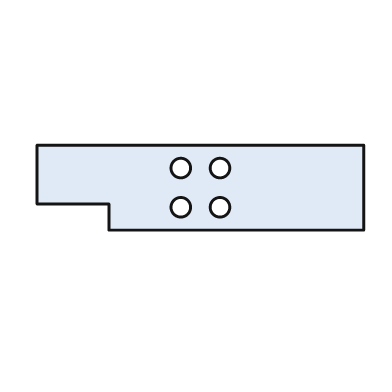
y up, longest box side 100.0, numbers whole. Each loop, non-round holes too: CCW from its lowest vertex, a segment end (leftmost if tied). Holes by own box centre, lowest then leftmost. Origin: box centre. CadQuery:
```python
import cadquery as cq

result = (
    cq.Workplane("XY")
    .moveTo(-28.0, -13.0)
    .lineTo(50.0, -13.0)
    .lineTo(50.0, 13.0)
    .lineTo(-50.0, 13.0)
    .lineTo(-50.0, -5.0)
    .lineTo(-28.0, -5.0)
    .close()
    .moveTo(-6.0, -6.0)
    .circle(3.0)
    .moveTo(6.0, -6.0)
    .circle(3.0)
    .moveTo(-6.0, 6.0)
    .circle(3.0)
    .moveTo(6.0, 6.0)
    .circle(3.0)
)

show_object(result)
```